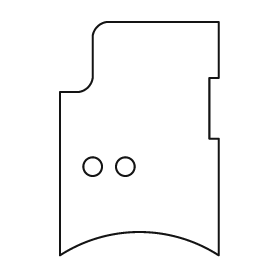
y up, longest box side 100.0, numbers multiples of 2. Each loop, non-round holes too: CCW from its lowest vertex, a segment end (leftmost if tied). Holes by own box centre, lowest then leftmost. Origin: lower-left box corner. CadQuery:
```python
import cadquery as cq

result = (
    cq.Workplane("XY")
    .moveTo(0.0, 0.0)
    .threePointArc((34.0, 10.0), (68.0, 0.0))
    .lineTo(68.0, 50.0)
    .lineTo(64.0, 50.0)
    .lineTo(64.0, 76.0)
    .lineTo(68.0, 76.0)
    .lineTo(68.0, 100.0)
    .lineTo(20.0, 100.0)
    .threePointArc((16.0, 98.0), (14.0, 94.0))
    .lineTo(14.0, 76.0)
    .threePointArc((12.0, 72.0), (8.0, 70.0))
    .lineTo(0.0, 70.0)
    .close()
    .moveTo(14.0, 38.0)
    .circle(4.0)
    .moveTo(28.0, 38.0)
    .circle(4.0)
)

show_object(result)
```